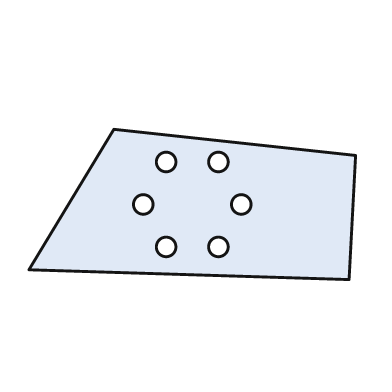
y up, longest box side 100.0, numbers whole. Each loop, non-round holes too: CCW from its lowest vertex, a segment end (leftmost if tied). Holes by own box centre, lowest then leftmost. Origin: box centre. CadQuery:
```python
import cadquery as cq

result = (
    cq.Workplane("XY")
    .moveTo(48.0, -23.0)
    .lineTo(50.0, 15.0)
    .lineTo(-24.0, 23.0)
    .lineTo(-50.0, -20.0)
    .close()
    .moveTo(-8.0, -13.0)
    .circle(3.0)
    .moveTo(8.0, -13.0)
    .circle(3.0)
    .moveTo(-15.0, 0.0)
    .circle(3.0)
    .moveTo(15.0, 0.0)
    .circle(3.0)
    .moveTo(-8.0, 13.0)
    .circle(3.0)
    .moveTo(8.0, 13.0)
    .circle(3.0)
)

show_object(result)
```